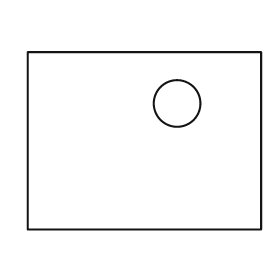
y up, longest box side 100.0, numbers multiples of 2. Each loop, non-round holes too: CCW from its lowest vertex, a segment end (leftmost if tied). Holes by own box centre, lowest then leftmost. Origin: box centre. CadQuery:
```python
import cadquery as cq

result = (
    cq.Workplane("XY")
    .moveTo(-50.0, -38.0)
    .lineTo(50.0, -38.0)
    .lineTo(50.0, 38.0)
    .lineTo(-50.0, 38.0)
    .close()
    .moveTo(14.0, 16.0)
    .circle(10.0)
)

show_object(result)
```